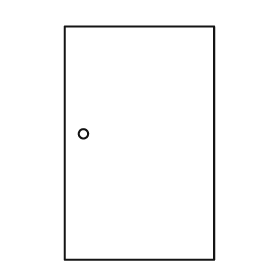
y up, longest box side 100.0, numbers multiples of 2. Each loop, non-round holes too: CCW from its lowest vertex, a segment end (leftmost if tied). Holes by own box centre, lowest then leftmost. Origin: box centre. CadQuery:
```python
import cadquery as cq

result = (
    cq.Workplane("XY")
    .moveTo(-32.0, -50.0)
    .lineTo(32.0, -50.0)
    .lineTo(32.0, 50.0)
    .lineTo(-32.0, 50.0)
    .close()
    .moveTo(-24.0, 4.0)
    .circle(2.0)
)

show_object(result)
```